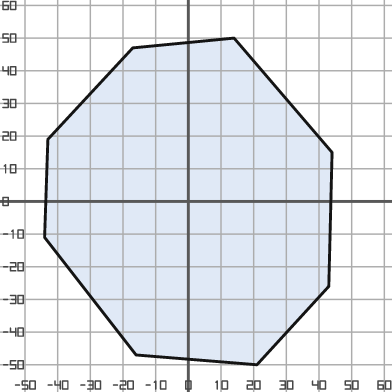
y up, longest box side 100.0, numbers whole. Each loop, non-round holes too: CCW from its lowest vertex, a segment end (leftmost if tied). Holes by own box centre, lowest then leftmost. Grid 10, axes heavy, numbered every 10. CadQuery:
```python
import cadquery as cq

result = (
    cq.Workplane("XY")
    .moveTo(21.0, -50.0)
    .lineTo(43.0, -26.0)
    .lineTo(44.0, 15.0)
    .lineTo(14.0, 50.0)
    .lineTo(-17.0, 47.0)
    .lineTo(-43.0, 19.0)
    .lineTo(-44.0, -11.0)
    .lineTo(-16.0, -47.0)
    .close()
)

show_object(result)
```